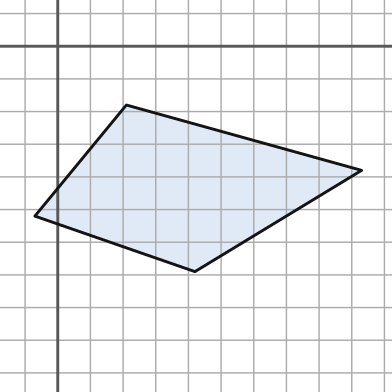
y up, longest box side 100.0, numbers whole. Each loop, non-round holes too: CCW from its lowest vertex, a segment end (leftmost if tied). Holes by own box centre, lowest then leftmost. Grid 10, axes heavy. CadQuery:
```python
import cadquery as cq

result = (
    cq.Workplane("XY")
    .moveTo(42.0, -69.0)
    .lineTo(93.0, -38.0)
    .lineTo(21.0, -18.0)
    .lineTo(-7.0, -52.0)
    .close()
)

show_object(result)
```